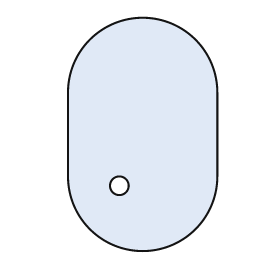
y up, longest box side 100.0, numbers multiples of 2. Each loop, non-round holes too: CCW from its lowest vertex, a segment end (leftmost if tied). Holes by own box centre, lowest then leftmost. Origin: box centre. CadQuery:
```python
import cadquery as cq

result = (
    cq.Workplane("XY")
    .moveTo(-32.0, -18.0)
    .threePointArc((0.0, -50.0), (32.0, -18.0))
    .lineTo(32.0, 18.0)
    .threePointArc((0.0, 50.0), (-32.0, 18.0))
    .close()
    .moveTo(-10.0, -22.0)
    .circle(4.0)
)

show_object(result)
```